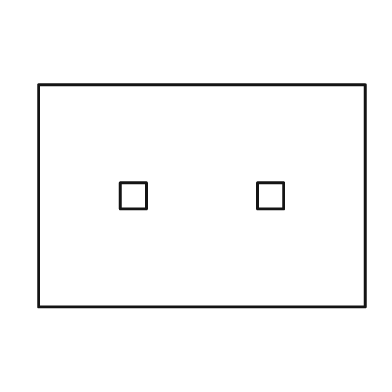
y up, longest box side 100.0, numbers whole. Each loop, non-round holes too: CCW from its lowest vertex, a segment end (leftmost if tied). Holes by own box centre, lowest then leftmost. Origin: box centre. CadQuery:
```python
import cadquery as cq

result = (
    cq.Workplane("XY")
    .moveTo(-50.0, -34.0)
    .lineTo(50.0, -34.0)
    .lineTo(50.0, 34.0)
    .lineTo(-50.0, 34.0)
    .close()
    .moveTo(-25.0, -4.0)
    .lineTo(-17.0, -4.0)
    .lineTo(-17.0, 4.0)
    .lineTo(-25.0, 4.0)
    .close()
    .moveTo(17.0, -4.0)
    .lineTo(25.0, -4.0)
    .lineTo(25.0, 4.0)
    .lineTo(17.0, 4.0)
    .close()
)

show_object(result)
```